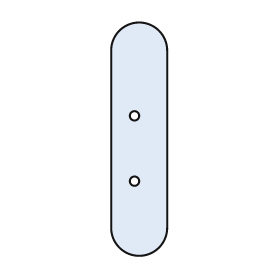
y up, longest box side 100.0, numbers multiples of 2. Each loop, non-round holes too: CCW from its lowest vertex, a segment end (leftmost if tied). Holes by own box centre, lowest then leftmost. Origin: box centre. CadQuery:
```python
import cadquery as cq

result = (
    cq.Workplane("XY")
    .moveTo(-12.0, -38.0)
    .threePointArc((0.0, -50.0), (12.0, -38.0))
    .lineTo(12.0, 38.0)
    .threePointArc((0.0, 50.0), (-12.0, 38.0))
    .close()
    .moveTo(-2.0, -18.0)
    .circle(2.0)
    .moveTo(-2.0, 10.0)
    .circle(2.0)
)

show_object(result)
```